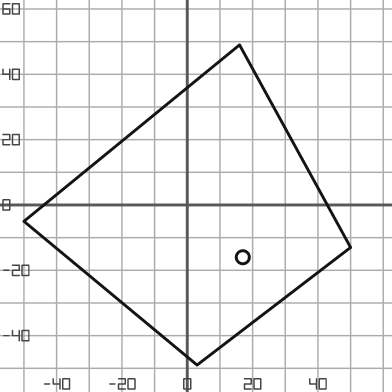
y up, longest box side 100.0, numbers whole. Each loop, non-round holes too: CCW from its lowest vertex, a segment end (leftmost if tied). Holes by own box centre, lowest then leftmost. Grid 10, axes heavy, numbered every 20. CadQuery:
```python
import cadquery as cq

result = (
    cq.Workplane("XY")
    .moveTo(3.0, -49.0)
    .lineTo(50.0, -13.0)
    .lineTo(16.0, 49.0)
    .lineTo(-50.0, -5.0)
    .close()
    .moveTo(17.0, -16.0)
    .circle(2.0)
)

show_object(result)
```